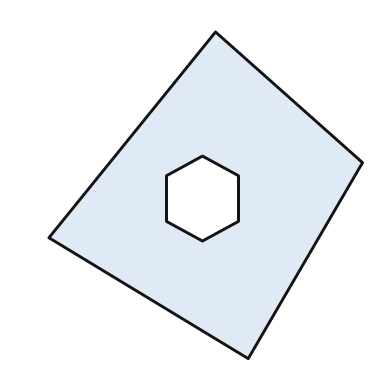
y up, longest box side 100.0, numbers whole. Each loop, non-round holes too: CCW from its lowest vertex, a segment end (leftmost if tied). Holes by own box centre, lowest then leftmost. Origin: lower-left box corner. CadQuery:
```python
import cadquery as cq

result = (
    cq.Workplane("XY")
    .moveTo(61.0, 0.0)
    .lineTo(96.0, 60.0)
    .lineTo(51.0, 100.0)
    .lineTo(0.0, 37.0)
    .close()
    .moveTo(47.0, 36.0)
    .lineTo(58.0, 42.0)
    .lineTo(58.0, 56.0)
    .lineTo(47.0, 62.0)
    .lineTo(36.0, 56.0)
    .lineTo(36.0, 42.0)
    .close()
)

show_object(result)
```